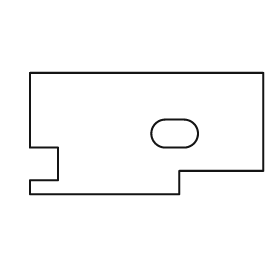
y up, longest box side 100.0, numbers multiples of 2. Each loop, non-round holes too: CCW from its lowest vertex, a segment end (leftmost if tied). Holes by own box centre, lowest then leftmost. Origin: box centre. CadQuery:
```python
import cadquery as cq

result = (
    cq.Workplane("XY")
    .moveTo(-50.0, -26.0)
    .lineTo(14.0, -26.0)
    .lineTo(14.0, -16.0)
    .lineTo(50.0, -16.0)
    .lineTo(50.0, 26.0)
    .lineTo(-50.0, 26.0)
    .lineTo(-50.0, -6.0)
    .lineTo(-38.0, -6.0)
    .lineTo(-38.0, -20.0)
    .lineTo(-50.0, -20.0)
    .close()
    .moveTo(8.0, -6.0)
    .lineTo(16.0, -6.0)
    .threePointArc((22.0, 0.0), (16.0, 6.0))
    .lineTo(8.0, 6.0)
    .threePointArc((2.0, 0.0), (8.0, -6.0))
    .close()
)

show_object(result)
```